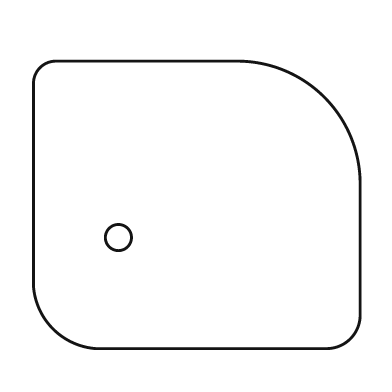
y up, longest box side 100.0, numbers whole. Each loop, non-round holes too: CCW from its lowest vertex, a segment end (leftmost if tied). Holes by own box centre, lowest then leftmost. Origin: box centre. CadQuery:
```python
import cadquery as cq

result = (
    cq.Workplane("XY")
    .moveTo(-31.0, -44.0)
    .lineTo(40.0, -44.0)
    .threePointArc((47.0, -41.0), (50.0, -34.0))
    .lineTo(50.0, 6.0)
    .threePointArc((39.0, 33.0), (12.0, 44.0))
    .lineTo(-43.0, 44.0)
    .threePointArc((-48.0, 42.0), (-50.0, 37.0))
    .lineTo(-50.0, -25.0)
    .threePointArc((-44.0, -38.0), (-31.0, -44.0))
    .close()
    .moveTo(-24.0, -10.0)
    .circle(4.0)
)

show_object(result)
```